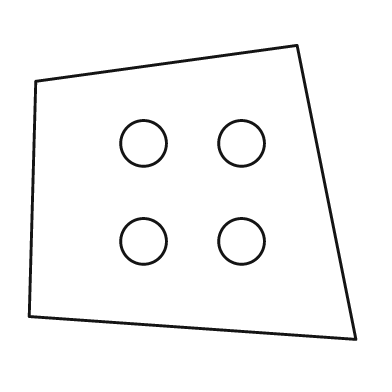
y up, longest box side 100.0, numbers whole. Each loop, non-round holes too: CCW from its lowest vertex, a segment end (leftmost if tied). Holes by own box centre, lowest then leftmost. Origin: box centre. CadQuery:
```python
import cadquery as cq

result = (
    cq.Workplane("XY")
    .moveTo(50.0, -45.0)
    .lineTo(32.0, 45.0)
    .lineTo(-48.0, 34.0)
    .lineTo(-50.0, -38.0)
    .close()
    .moveTo(-15.0, -15.0)
    .circle(7.0)
    .moveTo(15.0, -15.0)
    .circle(7.0)
    .moveTo(-15.0, 15.0)
    .circle(7.0)
    .moveTo(15.0, 15.0)
    .circle(7.0)
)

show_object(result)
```